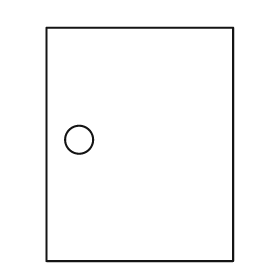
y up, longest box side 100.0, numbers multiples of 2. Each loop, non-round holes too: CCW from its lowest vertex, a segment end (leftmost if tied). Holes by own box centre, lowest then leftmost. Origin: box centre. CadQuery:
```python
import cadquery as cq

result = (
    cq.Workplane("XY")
    .moveTo(-40.0, -50.0)
    .lineTo(40.0, -50.0)
    .lineTo(40.0, 50.0)
    .lineTo(-40.0, 50.0)
    .close()
    .moveTo(-26.0, 2.0)
    .circle(6.0)
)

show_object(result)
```